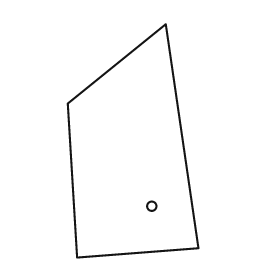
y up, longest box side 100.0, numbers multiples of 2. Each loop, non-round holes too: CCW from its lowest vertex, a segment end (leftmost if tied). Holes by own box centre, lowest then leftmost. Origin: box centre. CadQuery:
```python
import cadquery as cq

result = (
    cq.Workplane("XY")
    .moveTo(-24.0, -50.0)
    .lineTo(28.0, -46.0)
    .lineTo(14.0, 50.0)
    .lineTo(-28.0, 16.0)
    .close()
    .moveTo(8.0, -28.0)
    .circle(2.0)
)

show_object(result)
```